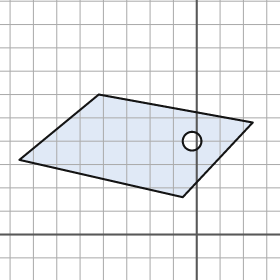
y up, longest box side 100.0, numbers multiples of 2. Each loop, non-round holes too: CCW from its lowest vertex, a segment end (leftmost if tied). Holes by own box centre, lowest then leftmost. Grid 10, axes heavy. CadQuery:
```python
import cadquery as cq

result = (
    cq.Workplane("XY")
    .moveTo(-6.0, 16.0)
    .lineTo(24.0, 48.0)
    .lineTo(-42.0, 60.0)
    .lineTo(-76.0, 32.0)
    .close()
    .moveTo(-2.0, 40.0)
    .circle(4.0)
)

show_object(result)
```